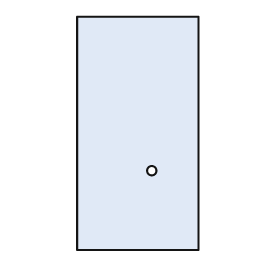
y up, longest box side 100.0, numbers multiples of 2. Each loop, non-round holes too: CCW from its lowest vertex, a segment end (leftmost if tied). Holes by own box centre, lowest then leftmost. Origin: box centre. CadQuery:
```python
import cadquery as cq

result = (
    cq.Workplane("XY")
    .moveTo(-26.0, -50.0)
    .lineTo(26.0, -50.0)
    .lineTo(26.0, 50.0)
    .lineTo(-26.0, 50.0)
    .close()
    .moveTo(6.0, -16.0)
    .circle(2.0)
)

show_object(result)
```